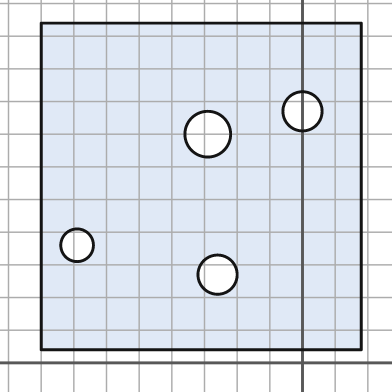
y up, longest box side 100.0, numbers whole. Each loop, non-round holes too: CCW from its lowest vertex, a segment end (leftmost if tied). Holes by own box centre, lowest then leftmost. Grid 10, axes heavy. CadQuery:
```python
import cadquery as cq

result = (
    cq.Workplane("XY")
    .moveTo(-80.0, 4.0)
    .lineTo(18.0, 4.0)
    .lineTo(18.0, 104.0)
    .lineTo(-80.0, 104.0)
    .close()
    .moveTo(-26.0, 27.0)
    .circle(6.0)
    .moveTo(-69.0, 36.0)
    .circle(5.0)
    .moveTo(-29.0, 70.0)
    .circle(7.0)
    .moveTo(0.0, 77.0)
    .circle(6.0)
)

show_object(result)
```